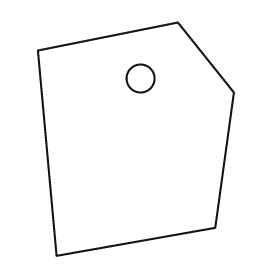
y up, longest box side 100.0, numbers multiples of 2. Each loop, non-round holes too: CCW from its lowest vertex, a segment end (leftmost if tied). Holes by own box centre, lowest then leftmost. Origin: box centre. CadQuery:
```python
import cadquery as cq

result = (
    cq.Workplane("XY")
    .moveTo(-34.0, -50.0)
    .lineTo(34.0, -38.0)
    .lineTo(42.0, 20.0)
    .lineTo(18.0, 50.0)
    .lineTo(-42.0, 38.0)
    .close()
    .moveTo(2.0, 26.0)
    .circle(6.0)
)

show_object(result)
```